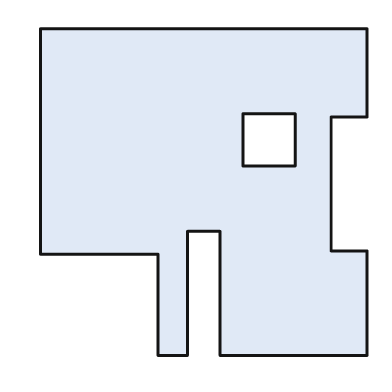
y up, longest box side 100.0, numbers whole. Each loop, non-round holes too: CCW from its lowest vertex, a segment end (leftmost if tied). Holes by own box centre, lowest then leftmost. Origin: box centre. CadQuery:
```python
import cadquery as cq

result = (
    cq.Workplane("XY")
    .moveTo(-14.0, -50.0)
    .lineTo(-5.0, -50.0)
    .lineTo(-5.0, -12.0)
    .lineTo(5.0, -12.0)
    .lineTo(5.0, -50.0)
    .lineTo(50.0, -50.0)
    .lineTo(50.0, -18.0)
    .lineTo(39.0, -18.0)
    .lineTo(39.0, 23.0)
    .lineTo(50.0, 23.0)
    .lineTo(50.0, 50.0)
    .lineTo(-50.0, 50.0)
    .lineTo(-50.0, -19.0)
    .lineTo(-14.0, -19.0)
    .close()
    .moveTo(12.0, 8.0)
    .lineTo(28.0, 8.0)
    .lineTo(28.0, 24.0)
    .lineTo(12.0, 24.0)
    .close()
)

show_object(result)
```